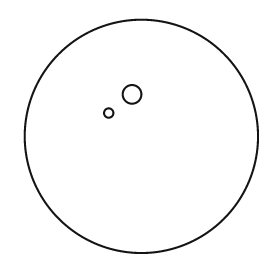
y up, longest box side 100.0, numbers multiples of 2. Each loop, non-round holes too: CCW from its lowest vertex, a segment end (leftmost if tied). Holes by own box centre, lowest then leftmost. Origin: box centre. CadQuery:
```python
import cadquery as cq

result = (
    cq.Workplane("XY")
    .moveTo(0.0, 0.0)
    .circle(50.0)
    .moveTo(-14.0, 10.0)
    .circle(2.0)
    .moveTo(-4.0, 18.0)
    .circle(4.0)
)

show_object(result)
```